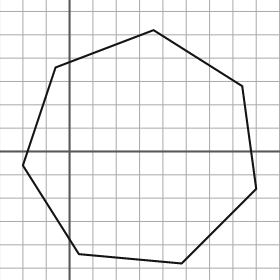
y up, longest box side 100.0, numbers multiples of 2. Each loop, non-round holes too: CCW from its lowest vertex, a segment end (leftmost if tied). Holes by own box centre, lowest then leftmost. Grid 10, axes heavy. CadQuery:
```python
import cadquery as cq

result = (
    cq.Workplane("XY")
    .moveTo(48.0, -48.0)
    .lineTo(80.0, -16.0)
    .lineTo(74.0, 28.0)
    .lineTo(36.0, 52.0)
    .lineTo(-6.0, 36.0)
    .lineTo(-20.0, -6.0)
    .lineTo(4.0, -44.0)
    .close()
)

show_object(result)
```